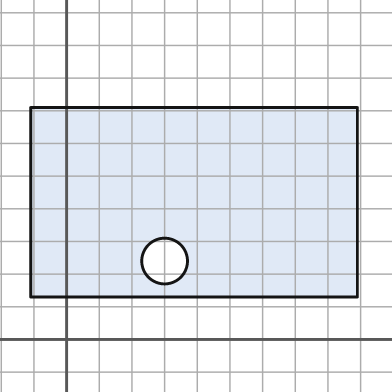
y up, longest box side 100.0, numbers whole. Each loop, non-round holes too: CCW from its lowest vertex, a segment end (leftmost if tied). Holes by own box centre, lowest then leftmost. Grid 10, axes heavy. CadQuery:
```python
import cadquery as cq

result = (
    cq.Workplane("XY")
    .moveTo(-11.0, 13.0)
    .lineTo(89.0, 13.0)
    .lineTo(89.0, 71.0)
    .lineTo(-11.0, 71.0)
    .close()
    .moveTo(30.0, 24.0)
    .circle(7.0)
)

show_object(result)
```